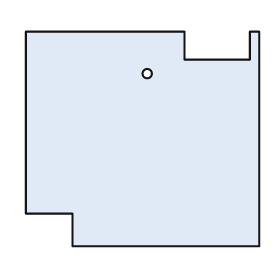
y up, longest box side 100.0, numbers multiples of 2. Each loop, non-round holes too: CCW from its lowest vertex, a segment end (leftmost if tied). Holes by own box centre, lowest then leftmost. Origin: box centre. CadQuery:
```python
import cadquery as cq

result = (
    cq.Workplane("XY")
    .moveTo(-30.0, -46.0)
    .lineTo(50.0, -46.0)
    .lineTo(50.0, 46.0)
    .lineTo(46.0, 46.0)
    .lineTo(46.0, 34.0)
    .lineTo(18.0, 34.0)
    .lineTo(18.0, 46.0)
    .lineTo(-50.0, 46.0)
    .lineTo(-50.0, -32.0)
    .lineTo(-30.0, -32.0)
    .close()
    .moveTo(2.0, 28.0)
    .circle(2.0)
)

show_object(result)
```